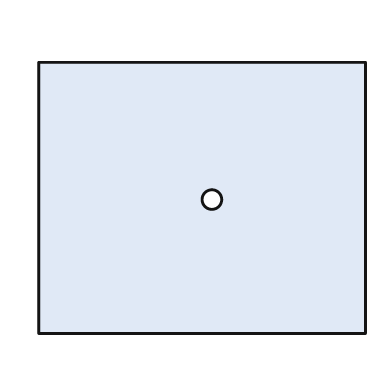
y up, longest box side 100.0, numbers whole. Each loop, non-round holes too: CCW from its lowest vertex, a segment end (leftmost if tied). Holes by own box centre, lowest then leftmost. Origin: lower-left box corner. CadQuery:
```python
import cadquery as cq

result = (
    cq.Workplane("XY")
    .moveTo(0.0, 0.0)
    .lineTo(100.0, 0.0)
    .lineTo(100.0, 83.0)
    .lineTo(0.0, 83.0)
    .close()
    .moveTo(53.0, 41.0)
    .circle(3.0)
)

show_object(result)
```